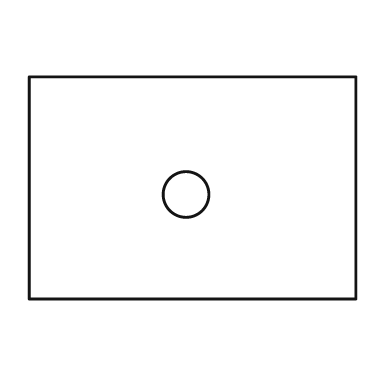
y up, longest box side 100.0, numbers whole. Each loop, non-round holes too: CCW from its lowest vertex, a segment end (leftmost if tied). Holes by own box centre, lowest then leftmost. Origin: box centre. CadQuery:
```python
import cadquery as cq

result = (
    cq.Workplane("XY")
    .moveTo(-50.0, -34.0)
    .lineTo(50.0, -34.0)
    .lineTo(50.0, 34.0)
    .lineTo(-50.0, 34.0)
    .close()
    .moveTo(-2.0, -2.0)
    .circle(7.0)
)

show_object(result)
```